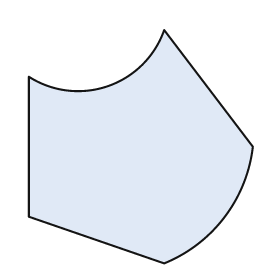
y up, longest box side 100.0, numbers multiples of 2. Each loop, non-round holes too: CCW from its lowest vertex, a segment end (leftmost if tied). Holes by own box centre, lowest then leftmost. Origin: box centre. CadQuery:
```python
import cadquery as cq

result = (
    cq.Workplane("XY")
    .moveTo(10.0, -50.0)
    .threePointArc((36.0, -30.0), (48.0, 0.0))
    .lineTo(10.0, 50.0)
    .threePointArc((-14.0, 26.0), (-48.0, 30.0))
    .lineTo(-48.0, -30.0)
    .close()
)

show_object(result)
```